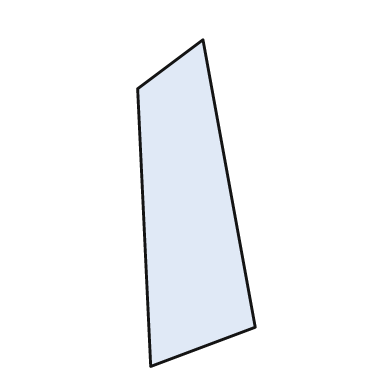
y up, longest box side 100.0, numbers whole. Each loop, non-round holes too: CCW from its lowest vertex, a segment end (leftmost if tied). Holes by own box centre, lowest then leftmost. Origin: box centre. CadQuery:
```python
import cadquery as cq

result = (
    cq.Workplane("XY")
    .moveTo(-14.0, -50.0)
    .lineTo(18.0, -38.0)
    .lineTo(2.0, 50.0)
    .lineTo(-18.0, 35.0)
    .close()
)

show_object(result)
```